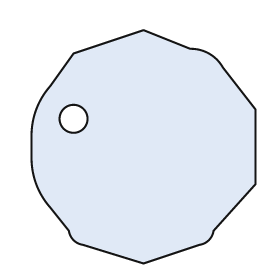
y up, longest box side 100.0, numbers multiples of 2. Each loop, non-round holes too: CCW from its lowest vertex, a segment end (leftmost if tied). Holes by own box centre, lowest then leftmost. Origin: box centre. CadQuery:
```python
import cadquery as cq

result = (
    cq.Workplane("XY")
    .moveTo(0.0, -50.0)
    .lineTo(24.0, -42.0)
    .threePointArc((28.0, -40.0), (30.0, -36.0))
    .lineTo(48.0, -16.0)
    .lineTo(48.0, 16.0)
    .lineTo(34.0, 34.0)
    .threePointArc((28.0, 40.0), (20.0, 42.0))
    .lineTo(0.0, 50.0)
    .lineTo(-30.0, 40.0)
    .lineTo(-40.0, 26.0)
    .threePointArc((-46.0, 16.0), (-48.0, 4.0))
    .lineTo(-48.0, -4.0)
    .threePointArc((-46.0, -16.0), (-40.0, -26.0))
    .lineTo(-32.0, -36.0)
    .threePointArc((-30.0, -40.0), (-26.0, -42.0))
    .close()
    .moveTo(-30.0, 12.0)
    .circle(6.0)
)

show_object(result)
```